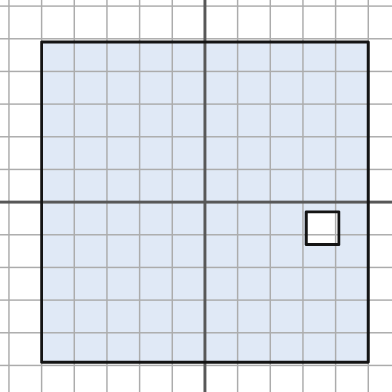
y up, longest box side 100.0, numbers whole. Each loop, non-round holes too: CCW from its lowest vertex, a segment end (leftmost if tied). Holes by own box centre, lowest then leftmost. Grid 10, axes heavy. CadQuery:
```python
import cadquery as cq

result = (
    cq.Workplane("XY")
    .moveTo(-50.0, -49.0)
    .lineTo(50.0, -49.0)
    .lineTo(50.0, 49.0)
    .lineTo(-50.0, 49.0)
    .close()
    .moveTo(31.0, -13.0)
    .lineTo(41.0, -13.0)
    .lineTo(41.0, -3.0)
    .lineTo(31.0, -3.0)
    .close()
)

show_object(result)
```